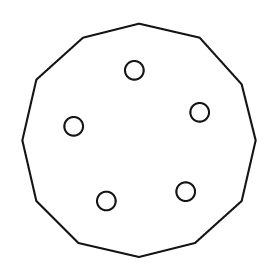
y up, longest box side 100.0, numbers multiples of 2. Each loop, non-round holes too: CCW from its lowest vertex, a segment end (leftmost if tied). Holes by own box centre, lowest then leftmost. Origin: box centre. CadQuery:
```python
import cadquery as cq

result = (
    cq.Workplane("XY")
    .moveTo(0.0, -50.0)
    .lineTo(24.0, -44.0)
    .lineTo(44.0, -26.0)
    .lineTo(50.0, 0.0)
    .lineTo(44.0, 24.0)
    .lineTo(26.0, 44.0)
    .lineTo(0.0, 50.0)
    .lineTo(-24.0, 44.0)
    .lineTo(-44.0, 26.0)
    .lineTo(-50.0, 0.0)
    .lineTo(-44.0, -26.0)
    .lineTo(-26.0, -44.0)
    .close()
    .moveTo(-14.0, -26.0)
    .circle(4.0)
    .moveTo(20.0, -22.0)
    .circle(4.0)
    .moveTo(-28.0, 6.0)
    .circle(4.0)
    .moveTo(26.0, 12.0)
    .circle(4.0)
    .moveTo(-2.0, 30.0)
    .circle(4.0)
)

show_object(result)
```